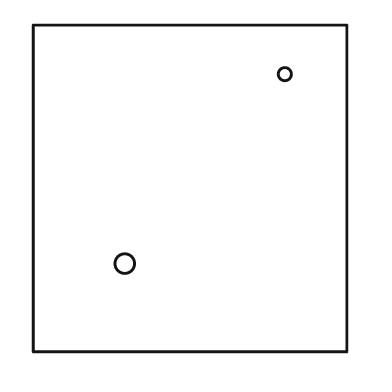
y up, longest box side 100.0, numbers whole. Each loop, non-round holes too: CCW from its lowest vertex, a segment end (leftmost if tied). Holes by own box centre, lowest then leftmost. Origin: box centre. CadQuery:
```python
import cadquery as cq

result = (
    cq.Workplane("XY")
    .moveTo(-48.0, -50.0)
    .lineTo(48.0, -50.0)
    .lineTo(48.0, 50.0)
    .lineTo(-48.0, 50.0)
    .close()
    .moveTo(-20.0, -23.0)
    .circle(3.0)
    .moveTo(29.0, 35.0)
    .circle(2.0)
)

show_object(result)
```